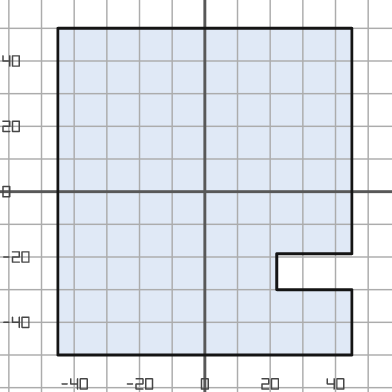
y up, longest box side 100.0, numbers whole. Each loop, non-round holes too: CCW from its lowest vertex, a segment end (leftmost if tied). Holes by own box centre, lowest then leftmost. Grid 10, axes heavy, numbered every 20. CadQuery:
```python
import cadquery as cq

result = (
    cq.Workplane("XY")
    .moveTo(-45.0, -50.0)
    .lineTo(45.0, -50.0)
    .lineTo(45.0, -30.0)
    .lineTo(22.0, -30.0)
    .lineTo(22.0, -19.0)
    .lineTo(45.0, -19.0)
    .lineTo(45.0, 50.0)
    .lineTo(-45.0, 50.0)
    .close()
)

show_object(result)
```